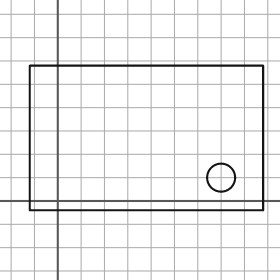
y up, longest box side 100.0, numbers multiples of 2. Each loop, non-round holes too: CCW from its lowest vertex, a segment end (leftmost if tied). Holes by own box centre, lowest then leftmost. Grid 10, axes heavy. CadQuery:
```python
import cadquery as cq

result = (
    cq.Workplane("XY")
    .moveTo(-12.0, -4.0)
    .lineTo(88.0, -4.0)
    .lineTo(88.0, 58.0)
    .lineTo(-12.0, 58.0)
    .close()
    .moveTo(70.0, 10.0)
    .circle(6.0)
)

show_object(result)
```